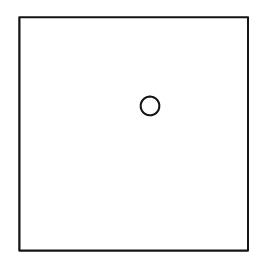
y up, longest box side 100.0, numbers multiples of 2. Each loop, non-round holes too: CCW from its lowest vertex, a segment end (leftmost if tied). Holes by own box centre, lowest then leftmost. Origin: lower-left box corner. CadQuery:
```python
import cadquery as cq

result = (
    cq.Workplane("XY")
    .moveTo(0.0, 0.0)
    .lineTo(98.0, 0.0)
    .lineTo(98.0, 100.0)
    .lineTo(0.0, 100.0)
    .close()
    .moveTo(56.0, 62.0)
    .circle(4.0)
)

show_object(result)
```